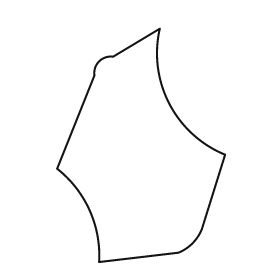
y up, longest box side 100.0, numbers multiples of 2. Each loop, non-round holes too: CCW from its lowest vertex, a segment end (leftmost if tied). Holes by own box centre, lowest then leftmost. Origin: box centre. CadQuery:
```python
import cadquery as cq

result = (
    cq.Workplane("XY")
    .moveTo(-18.0, -50.0)
    .lineTo(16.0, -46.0)
    .threePointArc((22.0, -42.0), (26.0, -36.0))
    .lineTo(36.0, -4.0)
    .threePointArc((12.0, 18.0), (8.0, 50.0))
    .lineTo(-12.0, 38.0)
    .threePointArc((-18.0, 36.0), (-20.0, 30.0))
    .lineTo(-36.0, -10.0)
    .threePointArc((-22.0, -28.0), (-18.0, -50.0))
    .close()
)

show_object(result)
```